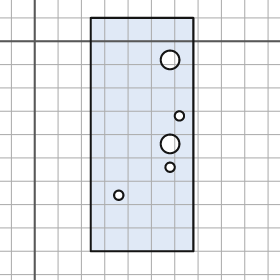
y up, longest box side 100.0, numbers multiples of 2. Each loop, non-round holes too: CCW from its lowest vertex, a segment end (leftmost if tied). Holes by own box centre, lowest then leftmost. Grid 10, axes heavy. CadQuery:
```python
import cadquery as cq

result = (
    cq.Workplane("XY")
    .moveTo(24.0, -90.0)
    .lineTo(68.0, -90.0)
    .lineTo(68.0, 10.0)
    .lineTo(24.0, 10.0)
    .close()
    .moveTo(36.0, -66.0)
    .circle(2.0)
    .moveTo(58.0, -54.0)
    .circle(2.0)
    .moveTo(58.0, -44.0)
    .circle(4.0)
    .moveTo(62.0, -32.0)
    .circle(2.0)
    .moveTo(58.0, -8.0)
    .circle(4.0)
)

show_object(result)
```